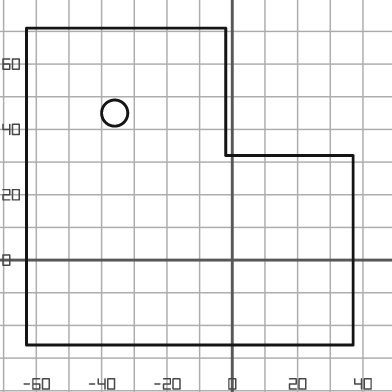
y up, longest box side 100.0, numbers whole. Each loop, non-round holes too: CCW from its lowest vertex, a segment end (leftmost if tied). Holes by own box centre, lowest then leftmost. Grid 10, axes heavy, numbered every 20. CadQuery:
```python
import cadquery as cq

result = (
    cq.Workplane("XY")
    .moveTo(-63.0, -26.0)
    .lineTo(37.0, -26.0)
    .lineTo(37.0, 32.0)
    .lineTo(-2.0, 32.0)
    .lineTo(-2.0, 71.0)
    .lineTo(-63.0, 71.0)
    .close()
    .moveTo(-36.0, 45.0)
    .circle(4.0)
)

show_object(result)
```